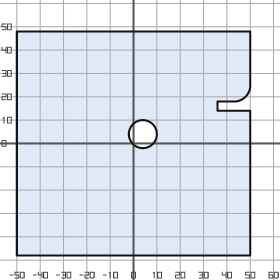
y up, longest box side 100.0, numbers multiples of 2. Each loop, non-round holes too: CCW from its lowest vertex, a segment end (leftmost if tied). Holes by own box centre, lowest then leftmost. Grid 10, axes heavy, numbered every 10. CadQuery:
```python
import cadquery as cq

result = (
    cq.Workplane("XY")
    .moveTo(-50.0, -48.0)
    .lineTo(50.0, -48.0)
    .lineTo(50.0, 14.0)
    .lineTo(36.0, 14.0)
    .lineTo(36.0, 18.0)
    .lineTo(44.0, 18.0)
    .threePointArc((48.0, 20.0), (50.0, 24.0))
    .lineTo(50.0, 48.0)
    .lineTo(-50.0, 48.0)
    .close()
    .moveTo(4.0, 4.0)
    .circle(6.0)
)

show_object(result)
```